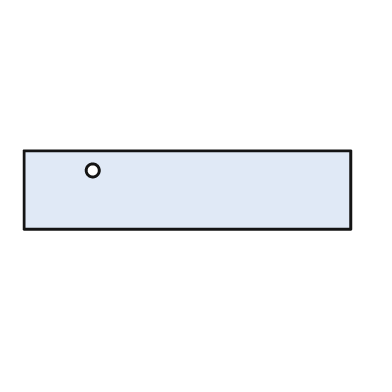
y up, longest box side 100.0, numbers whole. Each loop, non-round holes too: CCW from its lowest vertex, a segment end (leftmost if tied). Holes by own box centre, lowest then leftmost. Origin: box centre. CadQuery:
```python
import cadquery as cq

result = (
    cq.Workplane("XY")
    .moveTo(-50.0, -12.0)
    .lineTo(50.0, -12.0)
    .lineTo(50.0, 12.0)
    .lineTo(-50.0, 12.0)
    .close()
    .moveTo(-29.0, 6.0)
    .circle(2.0)
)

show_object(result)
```